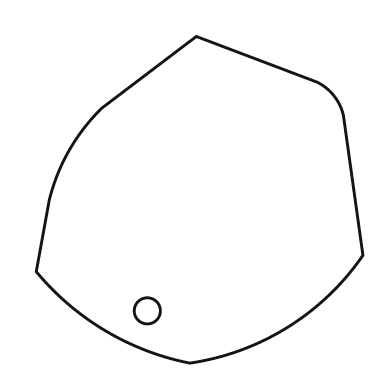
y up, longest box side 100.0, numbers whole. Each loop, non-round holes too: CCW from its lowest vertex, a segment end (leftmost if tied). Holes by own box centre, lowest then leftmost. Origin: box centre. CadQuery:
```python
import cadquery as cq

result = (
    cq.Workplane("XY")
    .moveTo(-3.0, -50.0)
    .threePointArc((27.0, -39.0), (50.0, -17.0))
    .lineTo(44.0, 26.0)
    .threePointArc((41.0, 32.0), (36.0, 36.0))
    .lineTo(-1.0, 50.0)
    .lineTo(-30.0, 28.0)
    .threePointArc((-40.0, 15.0), (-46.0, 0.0))
    .lineTo(-50.0, -22.0)
    .threePointArc((-29.0, -40.0), (-3.0, -50.0))
    .close()
    .moveTo(-16.0, -34.0)
    .circle(4.0)
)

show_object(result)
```